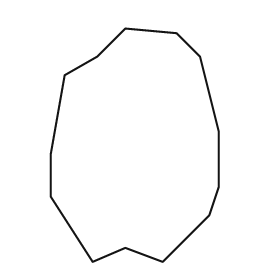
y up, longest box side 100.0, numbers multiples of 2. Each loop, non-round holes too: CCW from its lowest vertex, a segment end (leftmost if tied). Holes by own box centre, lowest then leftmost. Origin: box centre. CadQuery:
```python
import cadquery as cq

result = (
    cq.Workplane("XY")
    .moveTo(-18.0, -50.0)
    .lineTo(-4.0, -44.0)
    .lineTo(12.0, -50.0)
    .lineTo(32.0, -30.0)
    .lineTo(36.0, -18.0)
    .lineTo(36.0, 6.0)
    .lineTo(28.0, 38.0)
    .lineTo(18.0, 48.0)
    .lineTo(-4.0, 50.0)
    .lineTo(-16.0, 38.0)
    .lineTo(-30.0, 30.0)
    .lineTo(-36.0, -4.0)
    .lineTo(-36.0, -22.0)
    .close()
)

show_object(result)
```